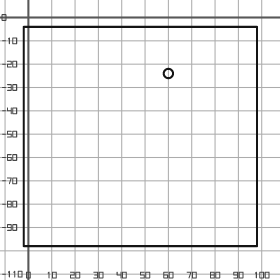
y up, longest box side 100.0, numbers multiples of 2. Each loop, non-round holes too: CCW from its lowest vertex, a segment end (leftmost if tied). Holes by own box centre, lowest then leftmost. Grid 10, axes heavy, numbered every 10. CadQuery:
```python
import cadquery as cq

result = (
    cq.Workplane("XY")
    .moveTo(-2.0, -98.0)
    .lineTo(98.0, -98.0)
    .lineTo(98.0, -4.0)
    .lineTo(-2.0, -4.0)
    .close()
    .moveTo(60.0, -24.0)
    .circle(2.0)
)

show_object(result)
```